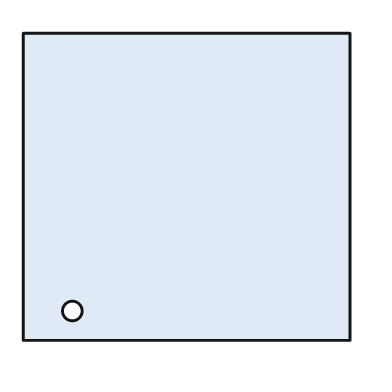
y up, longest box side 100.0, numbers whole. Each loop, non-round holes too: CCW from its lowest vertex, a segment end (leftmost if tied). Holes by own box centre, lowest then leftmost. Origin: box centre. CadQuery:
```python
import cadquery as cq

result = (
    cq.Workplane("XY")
    .moveTo(-50.0, -47.0)
    .lineTo(50.0, -47.0)
    .lineTo(50.0, 47.0)
    .lineTo(-50.0, 47.0)
    .close()
    .moveTo(-35.0, -38.0)
    .circle(3.0)
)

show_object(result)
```